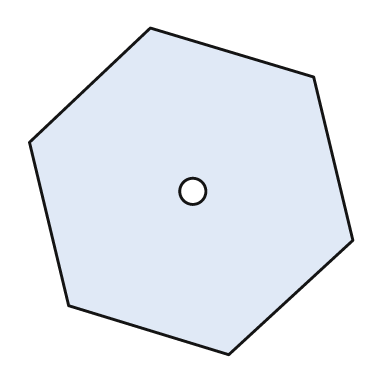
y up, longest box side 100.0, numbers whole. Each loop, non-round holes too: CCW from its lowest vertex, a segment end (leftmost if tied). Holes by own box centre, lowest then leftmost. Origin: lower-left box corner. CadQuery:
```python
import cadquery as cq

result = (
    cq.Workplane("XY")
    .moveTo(61.0, 0.0)
    .lineTo(99.0, 35.0)
    .lineTo(87.0, 85.0)
    .lineTo(37.0, 100.0)
    .lineTo(0.0, 65.0)
    .lineTo(12.0, 15.0)
    .close()
    .moveTo(50.0, 50.0)
    .circle(4.0)
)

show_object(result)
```